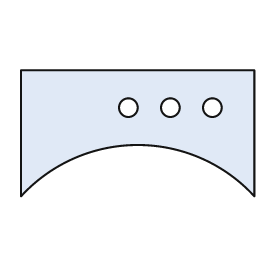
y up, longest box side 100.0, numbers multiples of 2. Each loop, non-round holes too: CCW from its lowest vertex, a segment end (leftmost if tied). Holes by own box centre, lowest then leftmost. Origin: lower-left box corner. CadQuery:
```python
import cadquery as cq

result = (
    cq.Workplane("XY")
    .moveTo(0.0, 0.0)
    .threePointArc((50.0, 22.0), (100.0, 0.0))
    .lineTo(100.0, 54.0)
    .lineTo(0.0, 54.0)
    .close()
    .moveTo(46.0, 38.0)
    .circle(4.0)
    .moveTo(64.0, 38.0)
    .circle(4.0)
    .moveTo(82.0, 38.0)
    .circle(4.0)
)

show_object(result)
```